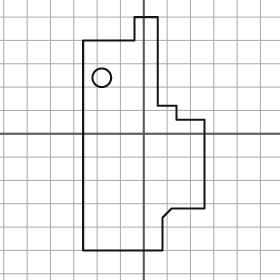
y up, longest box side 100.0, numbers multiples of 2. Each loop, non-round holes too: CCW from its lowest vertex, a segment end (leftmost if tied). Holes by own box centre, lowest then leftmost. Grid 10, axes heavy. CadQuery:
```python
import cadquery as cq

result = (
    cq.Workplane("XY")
    .moveTo(-26.0, -50.0)
    .lineTo(8.0, -50.0)
    .lineTo(8.0, -36.0)
    .lineTo(12.0, -32.0)
    .lineTo(26.0, -32.0)
    .lineTo(26.0, 6.0)
    .lineTo(14.0, 6.0)
    .lineTo(14.0, 12.0)
    .lineTo(6.0, 12.0)
    .lineTo(6.0, 50.0)
    .lineTo(-4.0, 50.0)
    .lineTo(-4.0, 40.0)
    .lineTo(-26.0, 40.0)
    .close()
    .moveTo(-18.0, 24.0)
    .circle(4.0)
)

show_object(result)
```